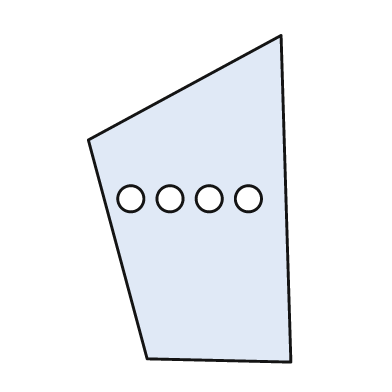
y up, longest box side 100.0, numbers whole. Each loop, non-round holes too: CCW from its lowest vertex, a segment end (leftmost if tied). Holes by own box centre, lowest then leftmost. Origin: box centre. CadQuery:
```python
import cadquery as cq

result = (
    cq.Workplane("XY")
    .moveTo(31.0, -50.0)
    .lineTo(28.0, 50.0)
    .lineTo(-31.0, 18.0)
    .lineTo(-13.0, -49.0)
    .close()
    .moveTo(-18.0, 0.0)
    .circle(4.0)
    .moveTo(-6.0, 0.0)
    .circle(4.0)
    .moveTo(6.0, 0.0)
    .circle(4.0)
    .moveTo(18.0, 0.0)
    .circle(4.0)
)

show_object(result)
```